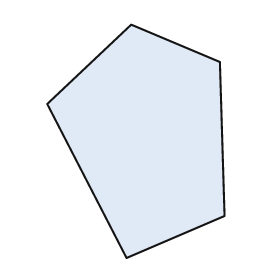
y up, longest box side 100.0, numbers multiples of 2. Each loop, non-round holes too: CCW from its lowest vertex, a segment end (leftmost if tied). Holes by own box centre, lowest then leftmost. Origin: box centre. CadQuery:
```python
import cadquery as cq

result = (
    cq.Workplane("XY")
    .moveTo(-4.0, -50.0)
    .lineTo(38.0, -32.0)
    .lineTo(36.0, 34.0)
    .lineTo(-2.0, 50.0)
    .lineTo(-38.0, 16.0)
    .close()
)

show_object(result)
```